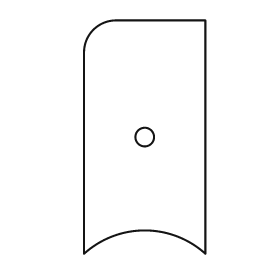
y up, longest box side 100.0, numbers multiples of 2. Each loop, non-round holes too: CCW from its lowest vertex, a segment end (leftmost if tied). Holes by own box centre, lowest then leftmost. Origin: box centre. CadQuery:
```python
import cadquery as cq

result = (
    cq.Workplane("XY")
    .moveTo(-26.0, -50.0)
    .threePointArc((0.0, -40.0), (26.0, -50.0))
    .lineTo(26.0, 50.0)
    .lineTo(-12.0, 50.0)
    .threePointArc((-22.0, 46.0), (-26.0, 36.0))
    .close()
    .moveTo(0.0, 0.0)
    .circle(4.0)
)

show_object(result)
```